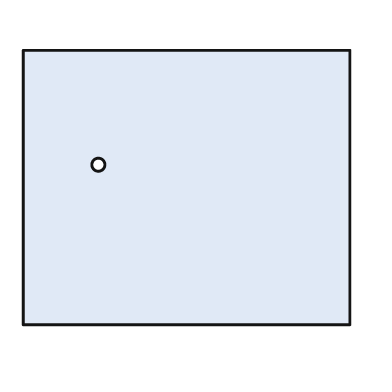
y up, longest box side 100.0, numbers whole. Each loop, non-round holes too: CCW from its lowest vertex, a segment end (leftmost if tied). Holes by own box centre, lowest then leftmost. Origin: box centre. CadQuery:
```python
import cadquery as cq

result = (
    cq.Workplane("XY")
    .moveTo(-50.0, -42.0)
    .lineTo(50.0, -42.0)
    .lineTo(50.0, 42.0)
    .lineTo(-50.0, 42.0)
    .close()
    .moveTo(-27.0, 7.0)
    .circle(2.0)
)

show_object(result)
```